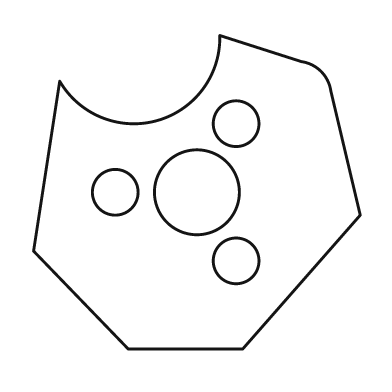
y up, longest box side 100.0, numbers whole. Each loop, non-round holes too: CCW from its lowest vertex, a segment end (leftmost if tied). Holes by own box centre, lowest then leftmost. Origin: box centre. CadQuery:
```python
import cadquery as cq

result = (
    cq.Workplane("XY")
    .moveTo(-21.0, -48.0)
    .lineTo(14.0, -48.0)
    .lineTo(50.0, -7.0)
    .lineTo(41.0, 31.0)
    .threePointArc((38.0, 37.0), (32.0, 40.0))
    .lineTo(7.0, 48.0)
    .threePointArc((-12.0, 22.0), (-42.0, 34.0))
    .lineTo(-50.0, -18.0)
    .close()
    .moveTo(12.0, -21.0)
    .circle(7.0)
    .moveTo(-25.0, 0.0)
    .circle(7.0)
    .moveTo(0.0, 0.0)
    .circle(13.0)
    .moveTo(12.0, 21.0)
    .circle(7.0)
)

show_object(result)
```